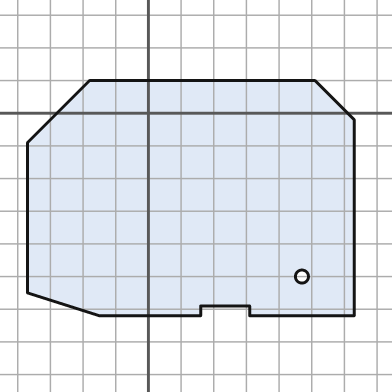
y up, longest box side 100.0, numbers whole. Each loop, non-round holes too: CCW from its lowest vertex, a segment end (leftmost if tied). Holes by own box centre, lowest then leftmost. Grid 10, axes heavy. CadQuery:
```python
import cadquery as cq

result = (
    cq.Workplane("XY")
    .moveTo(-15.0, -62.0)
    .lineTo(16.0, -62.0)
    .lineTo(16.0, -59.0)
    .lineTo(31.0, -59.0)
    .lineTo(31.0, -62.0)
    .lineTo(63.0, -62.0)
    .lineTo(63.0, -2.0)
    .lineTo(51.0, 10.0)
    .lineTo(-18.0, 10.0)
    .lineTo(-37.0, -9.0)
    .lineTo(-37.0, -55.0)
    .close()
    .moveTo(47.0, -50.0)
    .circle(2.0)
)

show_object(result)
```